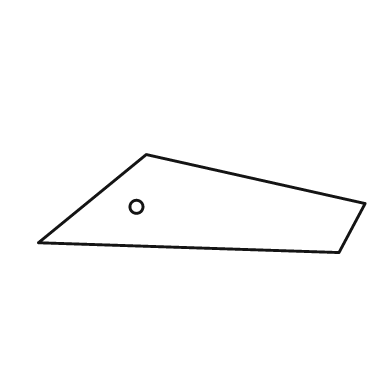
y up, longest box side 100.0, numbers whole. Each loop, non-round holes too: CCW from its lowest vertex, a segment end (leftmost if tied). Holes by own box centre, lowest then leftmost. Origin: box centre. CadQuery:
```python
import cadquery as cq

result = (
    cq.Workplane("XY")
    .moveTo(42.0, -15.0)
    .lineTo(50.0, 0.0)
    .lineTo(-17.0, 15.0)
    .lineTo(-50.0, -12.0)
    .close()
    .moveTo(-20.0, -1.0)
    .circle(2.0)
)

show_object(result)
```